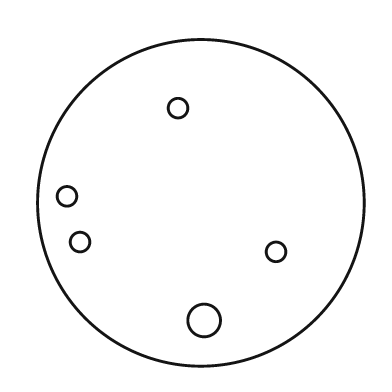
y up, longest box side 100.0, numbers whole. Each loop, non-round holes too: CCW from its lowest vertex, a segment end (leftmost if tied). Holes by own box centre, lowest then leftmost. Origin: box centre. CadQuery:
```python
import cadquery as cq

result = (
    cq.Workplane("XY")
    .moveTo(0.0, 0.0)
    .circle(50.0)
    .moveTo(1.0, -36.0)
    .circle(5.0)
    .moveTo(23.0, -15.0)
    .circle(3.0)
    .moveTo(-37.0, -12.0)
    .circle(3.0)
    .moveTo(-41.0, 2.0)
    .circle(3.0)
    .moveTo(-7.0, 29.0)
    .circle(3.0)
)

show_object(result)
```